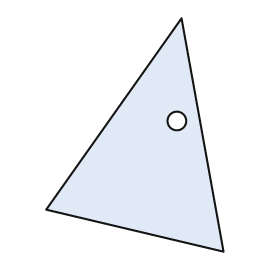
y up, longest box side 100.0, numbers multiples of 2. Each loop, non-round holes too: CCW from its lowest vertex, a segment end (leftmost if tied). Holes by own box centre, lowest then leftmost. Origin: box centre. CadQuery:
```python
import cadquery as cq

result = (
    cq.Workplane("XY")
    .moveTo(38.0, -50.0)
    .lineTo(20.0, 50.0)
    .lineTo(-38.0, -32.0)
    .close()
    .moveTo(18.0, 6.0)
    .circle(4.0)
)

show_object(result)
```